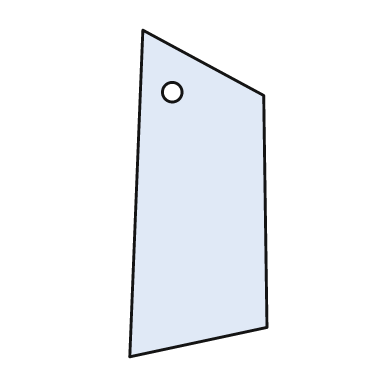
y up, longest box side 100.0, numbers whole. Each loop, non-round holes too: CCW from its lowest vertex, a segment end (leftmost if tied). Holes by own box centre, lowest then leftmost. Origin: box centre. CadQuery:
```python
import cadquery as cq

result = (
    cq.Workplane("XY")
    .moveTo(-21.0, -50.0)
    .lineTo(21.0, -41.0)
    .lineTo(20.0, 30.0)
    .lineTo(-17.0, 50.0)
    .close()
    .moveTo(-8.0, 31.0)
    .circle(3.0)
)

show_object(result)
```